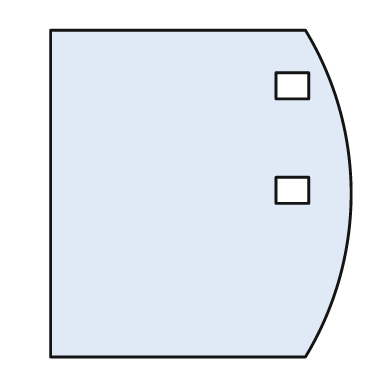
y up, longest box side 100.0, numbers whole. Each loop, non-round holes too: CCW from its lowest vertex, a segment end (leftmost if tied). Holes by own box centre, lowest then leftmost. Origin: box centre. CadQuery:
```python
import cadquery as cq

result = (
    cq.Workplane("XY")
    .moveTo(-46.0, -50.0)
    .lineTo(32.0, -50.0)
    .threePointArc((46.0, 0.0), (32.0, 50.0))
    .lineTo(-46.0, 50.0)
    .close()
    .moveTo(23.0, -3.0)
    .lineTo(33.0, -3.0)
    .lineTo(33.0, 5.0)
    .lineTo(23.0, 5.0)
    .close()
    .moveTo(23.0, 29.0)
    .lineTo(33.0, 29.0)
    .lineTo(33.0, 37.0)
    .lineTo(23.0, 37.0)
    .close()
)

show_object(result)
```